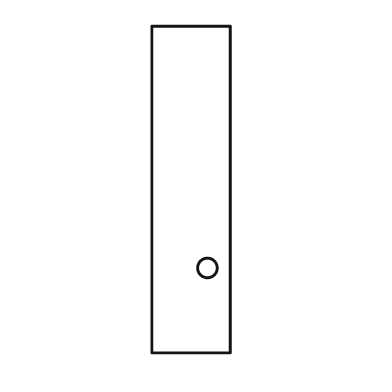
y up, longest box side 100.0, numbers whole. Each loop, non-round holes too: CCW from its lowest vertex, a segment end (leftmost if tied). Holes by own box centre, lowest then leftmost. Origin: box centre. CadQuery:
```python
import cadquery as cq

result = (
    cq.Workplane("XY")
    .moveTo(-12.0, -50.0)
    .lineTo(12.0, -50.0)
    .lineTo(12.0, 50.0)
    .lineTo(-12.0, 50.0)
    .close()
    .moveTo(5.0, -24.0)
    .circle(3.0)
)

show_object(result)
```